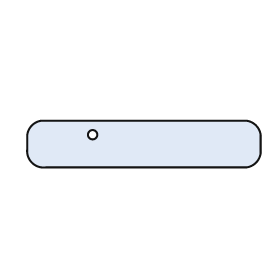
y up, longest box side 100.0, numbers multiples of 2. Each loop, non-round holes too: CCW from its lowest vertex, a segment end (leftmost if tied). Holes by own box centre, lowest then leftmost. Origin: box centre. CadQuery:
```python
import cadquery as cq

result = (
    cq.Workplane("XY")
    .moveTo(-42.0, -10.0)
    .lineTo(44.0, -10.0)
    .threePointArc((48.0, -8.0), (50.0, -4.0))
    .lineTo(50.0, 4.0)
    .threePointArc((48.0, 8.0), (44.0, 10.0))
    .lineTo(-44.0, 10.0)
    .threePointArc((-48.0, 8.0), (-50.0, 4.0))
    .lineTo(-50.0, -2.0)
    .threePointArc((-48.0, -8.0), (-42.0, -10.0))
    .close()
    .moveTo(-22.0, 4.0)
    .circle(2.0)
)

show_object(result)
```